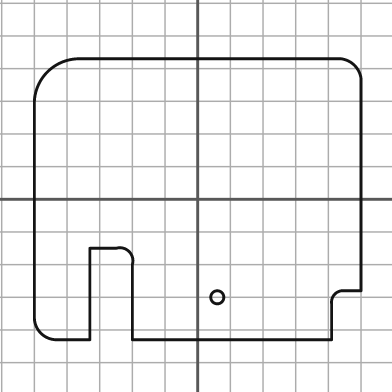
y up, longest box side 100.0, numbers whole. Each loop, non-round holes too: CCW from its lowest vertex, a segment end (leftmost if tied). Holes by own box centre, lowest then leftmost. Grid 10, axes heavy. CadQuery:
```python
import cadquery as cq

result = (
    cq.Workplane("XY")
    .moveTo(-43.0, -43.0)
    .lineTo(-33.0, -43.0)
    .lineTo(-33.0, -15.0)
    .lineTo(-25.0, -15.0)
    .threePointArc((-21.0, -16.0), (-20.0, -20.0))
    .lineTo(-20.0, -43.0)
    .lineTo(41.0, -43.0)
    .lineTo(41.0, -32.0)
    .threePointArc((42.0, -29.0), (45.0, -28.0))
    .lineTo(50.0, -28.0)
    .lineTo(50.0, 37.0)
    .threePointArc((48.0, 41.0), (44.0, 43.0))
    .lineTo(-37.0, 43.0)
    .threePointArc((-46.0, 39.0), (-50.0, 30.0))
    .lineTo(-50.0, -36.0)
    .threePointArc((-48.0, -41.0), (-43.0, -43.0))
    .close()
    .moveTo(6.0, -30.0)
    .circle(2.0)
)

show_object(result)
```